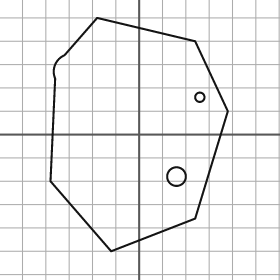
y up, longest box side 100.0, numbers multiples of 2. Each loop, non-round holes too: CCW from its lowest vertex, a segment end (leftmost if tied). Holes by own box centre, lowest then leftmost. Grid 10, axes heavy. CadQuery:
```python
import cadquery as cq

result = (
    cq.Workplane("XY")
    .moveTo(-12.0, -50.0)
    .lineTo(24.0, -36.0)
    .lineTo(38.0, 10.0)
    .lineTo(24.0, 40.0)
    .lineTo(-18.0, 50.0)
    .lineTo(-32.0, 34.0)
    .threePointArc((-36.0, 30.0), (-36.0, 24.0))
    .lineTo(-38.0, -20.0)
    .close()
    .moveTo(16.0, -18.0)
    .circle(4.0)
    .moveTo(26.0, 16.0)
    .circle(2.0)
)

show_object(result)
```